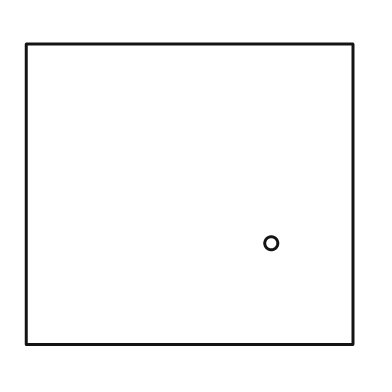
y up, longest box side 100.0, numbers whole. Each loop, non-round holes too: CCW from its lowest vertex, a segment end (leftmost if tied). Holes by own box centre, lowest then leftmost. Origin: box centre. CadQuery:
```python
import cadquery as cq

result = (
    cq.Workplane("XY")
    .moveTo(-50.0, -46.0)
    .lineTo(50.0, -46.0)
    .lineTo(50.0, 46.0)
    .lineTo(-50.0, 46.0)
    .close()
    .moveTo(25.0, -15.0)
    .circle(2.0)
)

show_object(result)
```